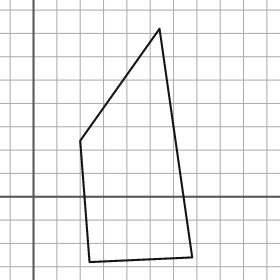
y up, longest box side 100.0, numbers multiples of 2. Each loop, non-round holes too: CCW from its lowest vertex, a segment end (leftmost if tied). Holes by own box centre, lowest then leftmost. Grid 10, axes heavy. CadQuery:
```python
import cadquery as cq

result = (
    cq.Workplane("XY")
    .moveTo(24.0, -28.0)
    .lineTo(68.0, -26.0)
    .lineTo(54.0, 72.0)
    .lineTo(20.0, 24.0)
    .close()
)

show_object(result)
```